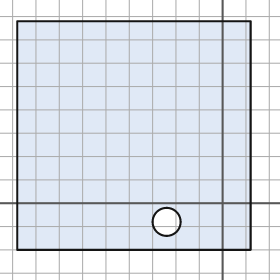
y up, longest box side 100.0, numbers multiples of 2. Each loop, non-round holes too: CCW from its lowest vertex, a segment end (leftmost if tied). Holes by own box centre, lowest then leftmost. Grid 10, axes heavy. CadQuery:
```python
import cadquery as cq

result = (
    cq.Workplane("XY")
    .moveTo(-88.0, -20.0)
    .lineTo(12.0, -20.0)
    .lineTo(12.0, 78.0)
    .lineTo(-88.0, 78.0)
    .close()
    .moveTo(-24.0, -8.0)
    .circle(6.0)
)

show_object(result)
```